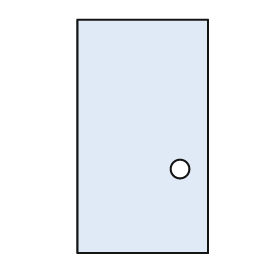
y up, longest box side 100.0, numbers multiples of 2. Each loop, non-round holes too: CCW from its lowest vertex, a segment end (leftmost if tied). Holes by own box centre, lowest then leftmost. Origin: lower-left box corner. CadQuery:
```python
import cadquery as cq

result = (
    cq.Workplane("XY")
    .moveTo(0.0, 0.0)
    .lineTo(56.0, 0.0)
    .lineTo(56.0, 100.0)
    .lineTo(0.0, 100.0)
    .close()
    .moveTo(44.0, 36.0)
    .circle(4.0)
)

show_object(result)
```